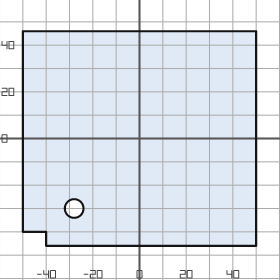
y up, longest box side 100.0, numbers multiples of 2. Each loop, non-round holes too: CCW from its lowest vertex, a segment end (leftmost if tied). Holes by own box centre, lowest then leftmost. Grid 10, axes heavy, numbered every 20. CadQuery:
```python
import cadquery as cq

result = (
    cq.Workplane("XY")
    .moveTo(-40.0, -46.0)
    .lineTo(50.0, -46.0)
    .lineTo(50.0, 46.0)
    .lineTo(-50.0, 46.0)
    .lineTo(-50.0, -40.0)
    .lineTo(-40.0, -40.0)
    .close()
    .moveTo(-28.0, -30.0)
    .circle(4.0)
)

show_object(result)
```